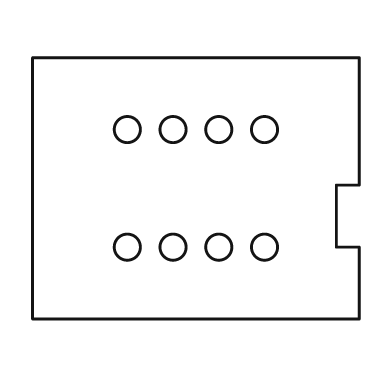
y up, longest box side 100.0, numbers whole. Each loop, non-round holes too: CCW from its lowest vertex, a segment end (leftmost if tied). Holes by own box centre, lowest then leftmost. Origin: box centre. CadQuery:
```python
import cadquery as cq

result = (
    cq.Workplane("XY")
    .moveTo(-50.0, -40.0)
    .lineTo(50.0, -40.0)
    .lineTo(50.0, -18.0)
    .lineTo(43.0, -18.0)
    .lineTo(43.0, 1.0)
    .lineTo(50.0, 1.0)
    .lineTo(50.0, 40.0)
    .lineTo(-50.0, 40.0)
    .close()
    .moveTo(-21.0, -18.0)
    .circle(4.0)
    .moveTo(-7.0, -18.0)
    .circle(4.0)
    .moveTo(7.0, -18.0)
    .circle(4.0)
    .moveTo(21.0, -18.0)
    .circle(4.0)
    .moveTo(-21.0, 18.0)
    .circle(4.0)
    .moveTo(-7.0, 18.0)
    .circle(4.0)
    .moveTo(7.0, 18.0)
    .circle(4.0)
    .moveTo(21.0, 18.0)
    .circle(4.0)
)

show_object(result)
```